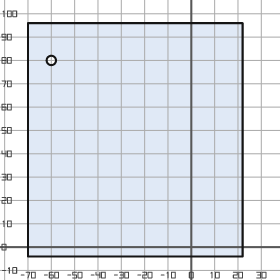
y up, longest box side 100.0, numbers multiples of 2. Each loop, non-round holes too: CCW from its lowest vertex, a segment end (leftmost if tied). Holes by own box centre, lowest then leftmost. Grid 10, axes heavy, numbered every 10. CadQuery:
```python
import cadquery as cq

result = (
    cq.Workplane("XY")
    .moveTo(-70.0, -4.0)
    .lineTo(22.0, -4.0)
    .lineTo(22.0, 96.0)
    .lineTo(-70.0, 96.0)
    .close()
    .moveTo(-60.0, 80.0)
    .circle(2.0)
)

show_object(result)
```